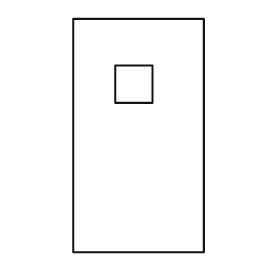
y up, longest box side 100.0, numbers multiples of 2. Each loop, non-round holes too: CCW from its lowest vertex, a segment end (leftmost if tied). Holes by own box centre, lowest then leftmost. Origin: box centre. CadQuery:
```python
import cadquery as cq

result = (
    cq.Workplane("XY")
    .moveTo(-28.0, -50.0)
    .lineTo(28.0, -50.0)
    .lineTo(28.0, 50.0)
    .lineTo(-28.0, 50.0)
    .close()
    .moveTo(-10.0, 14.0)
    .lineTo(6.0, 14.0)
    .lineTo(6.0, 30.0)
    .lineTo(-10.0, 30.0)
    .close()
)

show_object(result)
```